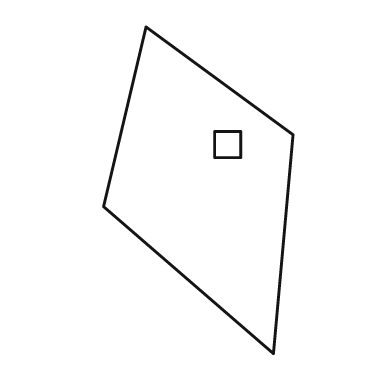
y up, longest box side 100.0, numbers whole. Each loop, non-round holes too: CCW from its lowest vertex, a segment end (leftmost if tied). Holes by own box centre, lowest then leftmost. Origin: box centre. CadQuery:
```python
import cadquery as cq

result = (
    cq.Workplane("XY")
    .moveTo(23.0, -50.0)
    .lineTo(29.0, 17.0)
    .lineTo(-16.0, 50.0)
    .lineTo(-29.0, -5.0)
    .close()
    .moveTo(5.0, 10.0)
    .lineTo(13.0, 10.0)
    .lineTo(13.0, 18.0)
    .lineTo(5.0, 18.0)
    .close()
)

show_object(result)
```